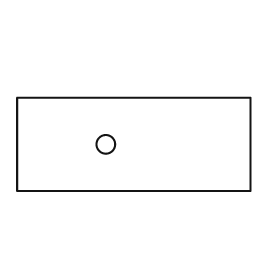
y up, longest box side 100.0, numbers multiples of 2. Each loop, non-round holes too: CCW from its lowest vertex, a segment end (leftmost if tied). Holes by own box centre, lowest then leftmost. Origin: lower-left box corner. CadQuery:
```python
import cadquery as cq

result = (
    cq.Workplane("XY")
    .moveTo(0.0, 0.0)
    .lineTo(100.0, 0.0)
    .lineTo(100.0, 40.0)
    .lineTo(0.0, 40.0)
    .close()
    .moveTo(38.0, 20.0)
    .circle(4.0)
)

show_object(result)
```